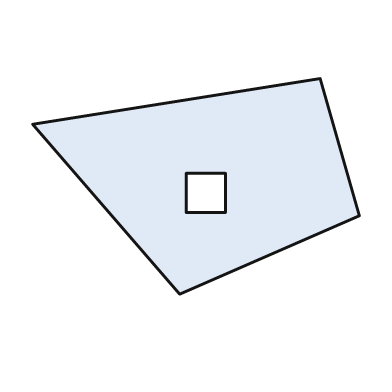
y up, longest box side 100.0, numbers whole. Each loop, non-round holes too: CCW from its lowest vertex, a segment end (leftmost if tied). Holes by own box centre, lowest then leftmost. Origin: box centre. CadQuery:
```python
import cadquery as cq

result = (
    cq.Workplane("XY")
    .moveTo(-5.0, -33.0)
    .lineTo(50.0, -9.0)
    .lineTo(38.0, 33.0)
    .lineTo(-50.0, 19.0)
    .close()
    .moveTo(-3.0, -8.0)
    .lineTo(9.0, -8.0)
    .lineTo(9.0, 4.0)
    .lineTo(-3.0, 4.0)
    .close()
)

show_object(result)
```